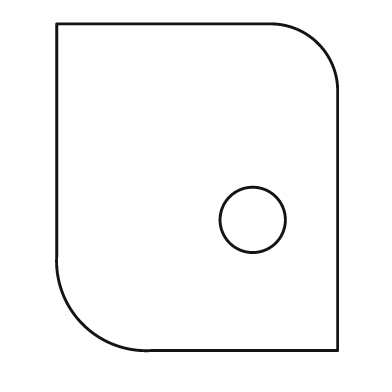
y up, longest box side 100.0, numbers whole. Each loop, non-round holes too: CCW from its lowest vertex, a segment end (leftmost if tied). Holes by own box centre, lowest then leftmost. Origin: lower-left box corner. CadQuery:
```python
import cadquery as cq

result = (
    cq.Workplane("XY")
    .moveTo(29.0, 0.0)
    .lineTo(86.0, 0.0)
    .lineTo(86.0, 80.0)
    .threePointArc((80.0, 94.0), (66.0, 100.0))
    .lineTo(0.0, 100.0)
    .lineTo(0.0, 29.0)
    .threePointArc((8.0, 8.0), (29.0, 0.0))
    .close()
    .moveTo(60.0, 40.0)
    .circle(10.0)
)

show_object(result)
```